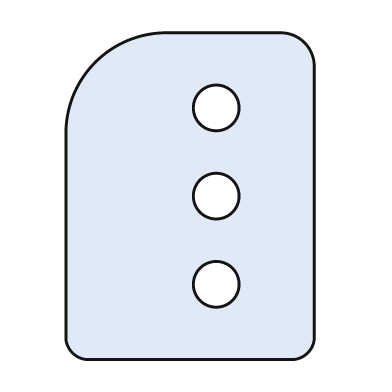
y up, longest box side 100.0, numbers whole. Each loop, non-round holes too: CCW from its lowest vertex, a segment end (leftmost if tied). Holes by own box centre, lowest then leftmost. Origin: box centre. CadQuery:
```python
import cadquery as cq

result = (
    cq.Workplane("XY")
    .moveTo(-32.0, -50.0)
    .lineTo(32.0, -50.0)
    .threePointArc((36.0, -48.0), (38.0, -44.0))
    .lineTo(38.0, 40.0)
    .threePointArc((35.0, 47.0), (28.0, 50.0))
    .lineTo(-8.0, 50.0)
    .threePointArc((-29.0, 41.0), (-38.0, 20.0))
    .lineTo(-38.0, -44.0)
    .threePointArc((-36.0, -48.0), (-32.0, -50.0))
    .close()
    .moveTo(8.0, -27.0)
    .circle(7.0)
    .moveTo(8.0, 0.0)
    .circle(7.0)
    .moveTo(8.0, 27.0)
    .circle(7.0)
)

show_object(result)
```